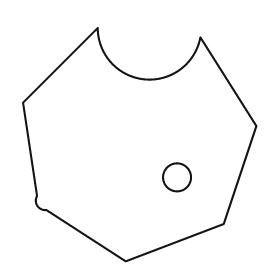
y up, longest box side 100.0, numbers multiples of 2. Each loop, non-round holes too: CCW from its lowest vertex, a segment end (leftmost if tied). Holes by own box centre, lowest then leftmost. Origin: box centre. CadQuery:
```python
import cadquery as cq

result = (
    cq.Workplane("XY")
    .moveTo(-6.0, -50.0)
    .lineTo(36.0, -34.0)
    .lineTo(50.0, 8.0)
    .lineTo(26.0, 46.0)
    .threePointArc((2.0, 28.0), (-18.0, 50.0))
    .lineTo(-50.0, 18.0)
    .lineTo(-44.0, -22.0)
    .threePointArc((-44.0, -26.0), (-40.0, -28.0))
    .close()
    .moveTo(16.0, -14.0)
    .circle(6.0)
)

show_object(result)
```